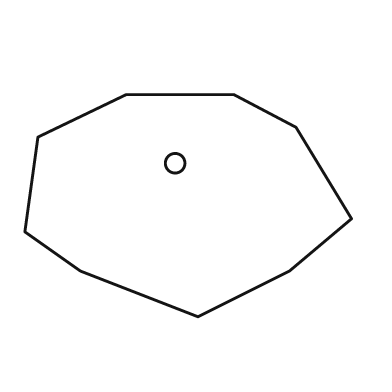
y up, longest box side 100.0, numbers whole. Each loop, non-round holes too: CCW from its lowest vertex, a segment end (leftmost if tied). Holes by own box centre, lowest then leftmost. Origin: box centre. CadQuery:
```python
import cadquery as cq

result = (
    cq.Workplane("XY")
    .moveTo(3.0, -34.0)
    .lineTo(31.0, -20.0)
    .lineTo(50.0, -4.0)
    .lineTo(33.0, 24.0)
    .lineTo(14.0, 34.0)
    .lineTo(-19.0, 34.0)
    .lineTo(-46.0, 21.0)
    .lineTo(-50.0, -8.0)
    .lineTo(-33.0, -20.0)
    .close()
    .moveTo(-4.0, 13.0)
    .circle(3.0)
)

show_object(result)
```